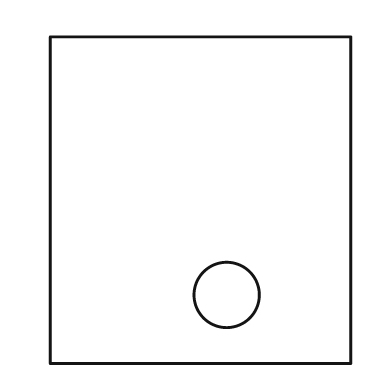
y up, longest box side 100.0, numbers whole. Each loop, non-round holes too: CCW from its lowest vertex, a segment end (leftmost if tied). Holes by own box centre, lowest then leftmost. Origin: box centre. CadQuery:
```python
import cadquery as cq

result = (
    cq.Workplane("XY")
    .moveTo(-46.0, -50.0)
    .lineTo(46.0, -50.0)
    .lineTo(46.0, 50.0)
    .lineTo(-46.0, 50.0)
    .close()
    .moveTo(8.0, -29.0)
    .circle(10.0)
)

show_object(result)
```